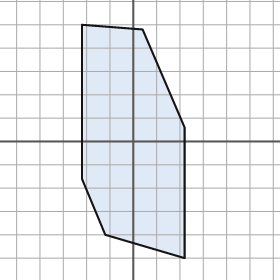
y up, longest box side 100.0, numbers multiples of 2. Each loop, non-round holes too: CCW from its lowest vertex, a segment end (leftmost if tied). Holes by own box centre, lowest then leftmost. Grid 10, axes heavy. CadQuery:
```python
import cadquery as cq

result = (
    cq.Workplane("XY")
    .moveTo(22.0, -50.0)
    .lineTo(22.0, 6.0)
    .lineTo(4.0, 48.0)
    .lineTo(-22.0, 50.0)
    .lineTo(-22.0, -16.0)
    .lineTo(-12.0, -40.0)
    .close()
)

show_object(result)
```